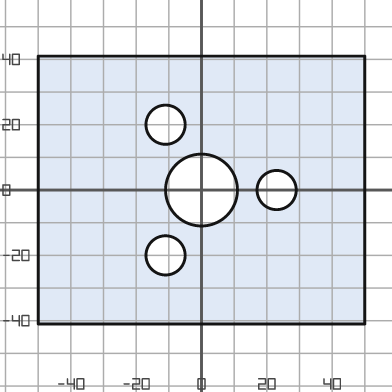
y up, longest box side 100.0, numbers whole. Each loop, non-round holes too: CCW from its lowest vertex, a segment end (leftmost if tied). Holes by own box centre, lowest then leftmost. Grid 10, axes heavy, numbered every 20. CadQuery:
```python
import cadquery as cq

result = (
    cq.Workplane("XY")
    .moveTo(-50.0, -41.0)
    .lineTo(50.0, -41.0)
    .lineTo(50.0, 41.0)
    .lineTo(-50.0, 41.0)
    .close()
    .moveTo(-11.0, -20.0)
    .circle(6.0)
    .moveTo(0.0, 0.0)
    .circle(11.0)
    .moveTo(23.0, 0.0)
    .circle(6.0)
    .moveTo(-11.0, 20.0)
    .circle(6.0)
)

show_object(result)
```